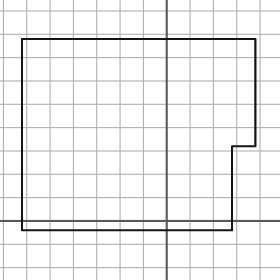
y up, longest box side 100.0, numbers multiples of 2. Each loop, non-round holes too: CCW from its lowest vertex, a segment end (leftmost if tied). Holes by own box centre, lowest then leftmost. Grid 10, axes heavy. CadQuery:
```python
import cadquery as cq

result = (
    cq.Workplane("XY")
    .moveTo(-62.0, -4.0)
    .lineTo(28.0, -4.0)
    .lineTo(28.0, 32.0)
    .lineTo(38.0, 32.0)
    .lineTo(38.0, 78.0)
    .lineTo(-62.0, 78.0)
    .close()
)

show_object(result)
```